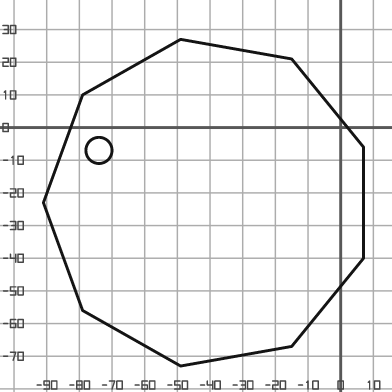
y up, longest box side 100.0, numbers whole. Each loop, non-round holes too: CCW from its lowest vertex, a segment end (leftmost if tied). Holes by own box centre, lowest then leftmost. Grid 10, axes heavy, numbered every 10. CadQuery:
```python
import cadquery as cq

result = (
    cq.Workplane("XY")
    .moveTo(-49.0, -73.0)
    .lineTo(-15.0, -67.0)
    .lineTo(7.0, -40.0)
    .lineTo(7.0, -6.0)
    .lineTo(-15.0, 21.0)
    .lineTo(-49.0, 27.0)
    .lineTo(-79.0, 10.0)
    .lineTo(-91.0, -23.0)
    .lineTo(-79.0, -56.0)
    .close()
    .moveTo(-74.0, -7.0)
    .circle(4.0)
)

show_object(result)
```